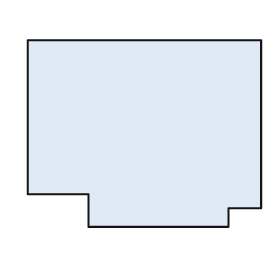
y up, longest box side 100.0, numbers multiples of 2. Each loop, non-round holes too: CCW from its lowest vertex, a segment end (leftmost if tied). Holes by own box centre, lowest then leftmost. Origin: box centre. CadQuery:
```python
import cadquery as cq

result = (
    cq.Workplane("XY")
    .moveTo(-24.0, -40.0)
    .lineTo(36.0, -40.0)
    .lineTo(36.0, -32.0)
    .lineTo(50.0, -32.0)
    .lineTo(50.0, 40.0)
    .lineTo(-50.0, 40.0)
    .lineTo(-50.0, -26.0)
    .lineTo(-24.0, -26.0)
    .close()
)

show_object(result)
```